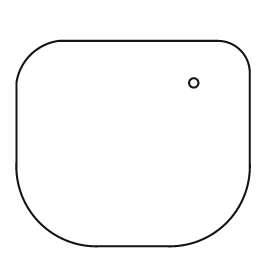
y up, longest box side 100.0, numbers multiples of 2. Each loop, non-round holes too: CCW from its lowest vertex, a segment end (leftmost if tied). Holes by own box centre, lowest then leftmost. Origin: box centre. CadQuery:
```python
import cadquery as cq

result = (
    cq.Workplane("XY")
    .moveTo(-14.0, -44.0)
    .lineTo(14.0, -44.0)
    .threePointArc((40.0, -34.0), (50.0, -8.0))
    .lineTo(50.0, 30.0)
    .threePointArc((46.0, 40.0), (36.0, 44.0))
    .lineTo(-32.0, 44.0)
    .threePointArc((-44.0, 38.0), (-50.0, 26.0))
    .lineTo(-50.0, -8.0)
    .threePointArc((-40.0, -34.0), (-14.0, -44.0))
    .close()
    .moveTo(26.0, 26.0)
    .circle(2.0)
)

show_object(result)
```